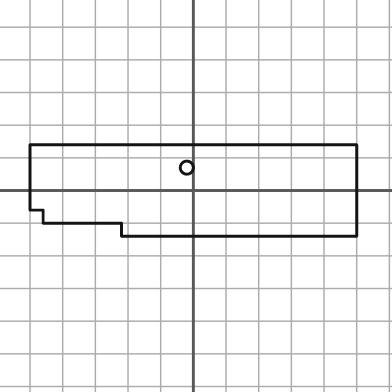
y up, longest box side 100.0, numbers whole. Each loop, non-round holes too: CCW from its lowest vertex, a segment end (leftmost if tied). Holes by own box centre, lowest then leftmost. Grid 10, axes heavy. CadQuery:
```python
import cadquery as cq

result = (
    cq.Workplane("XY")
    .moveTo(-22.0, -14.0)
    .lineTo(50.0, -14.0)
    .lineTo(50.0, 14.0)
    .lineTo(-50.0, 14.0)
    .lineTo(-50.0, -6.0)
    .lineTo(-46.0, -6.0)
    .lineTo(-46.0, -10.0)
    .lineTo(-22.0, -10.0)
    .close()
    .moveTo(-2.0, 7.0)
    .circle(2.0)
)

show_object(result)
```